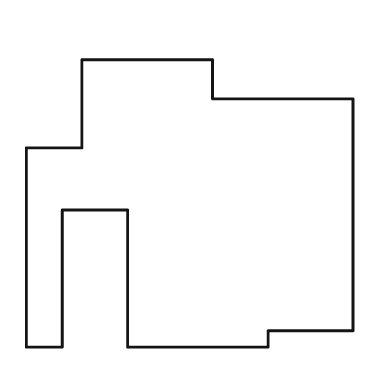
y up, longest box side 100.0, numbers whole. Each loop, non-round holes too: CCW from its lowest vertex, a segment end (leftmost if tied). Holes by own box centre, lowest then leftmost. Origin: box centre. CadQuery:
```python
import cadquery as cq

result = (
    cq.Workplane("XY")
    .moveTo(-50.0, -44.0)
    .lineTo(-39.0, -44.0)
    .lineTo(-39.0, -2.0)
    .lineTo(-19.0, -2.0)
    .lineTo(-19.0, -44.0)
    .lineTo(24.0, -44.0)
    .lineTo(24.0, -39.0)
    .lineTo(50.0, -39.0)
    .lineTo(50.0, 32.0)
    .lineTo(7.0, 32.0)
    .lineTo(7.0, 44.0)
    .lineTo(-33.0, 44.0)
    .lineTo(-33.0, 17.0)
    .lineTo(-50.0, 17.0)
    .close()
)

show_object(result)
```